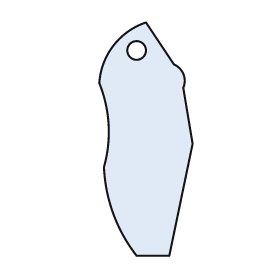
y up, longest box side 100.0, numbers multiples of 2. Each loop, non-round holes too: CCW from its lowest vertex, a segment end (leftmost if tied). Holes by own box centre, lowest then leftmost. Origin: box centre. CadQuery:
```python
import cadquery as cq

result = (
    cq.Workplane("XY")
    .moveTo(-4.0, -50.0)
    .lineTo(10.0, -50.0)
    .lineTo(20.0, -2.0)
    .lineTo(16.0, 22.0)
    .threePointArc((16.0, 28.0), (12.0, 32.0))
    .lineTo(0.0, 50.0)
    .threePointArc((-14.0, 40.0), (-20.0, 24.0))
    .threePointArc((-16.0, 6.0), (-18.0, -12.0))
    .threePointArc((-14.0, -32.0), (-4.0, -50.0))
    .close()
    .moveTo(-4.0, 38.0)
    .circle(4.0)
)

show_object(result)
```